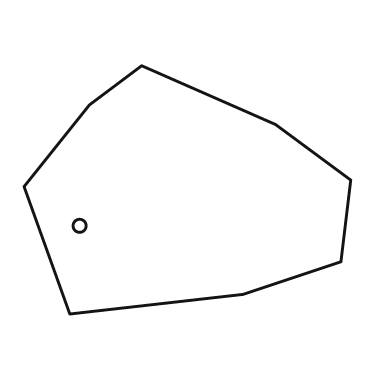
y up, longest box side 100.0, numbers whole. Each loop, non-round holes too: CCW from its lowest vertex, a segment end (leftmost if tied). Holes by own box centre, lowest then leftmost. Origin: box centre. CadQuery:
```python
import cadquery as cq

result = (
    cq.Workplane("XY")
    .moveTo(-36.0, -38.0)
    .lineTo(17.0, -32.0)
    .lineTo(47.0, -22.0)
    .lineTo(50.0, 3.0)
    .lineTo(27.0, 20.0)
    .lineTo(-14.0, 38.0)
    .lineTo(-30.0, 26.0)
    .lineTo(-50.0, 1.0)
    .close()
    .moveTo(-33.0, -11.0)
    .circle(2.0)
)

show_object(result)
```